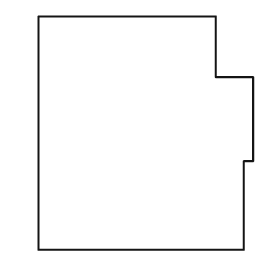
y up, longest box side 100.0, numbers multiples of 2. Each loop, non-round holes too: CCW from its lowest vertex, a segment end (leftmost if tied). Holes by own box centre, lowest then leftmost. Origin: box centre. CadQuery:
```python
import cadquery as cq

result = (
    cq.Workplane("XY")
    .moveTo(-46.0, -50.0)
    .lineTo(42.0, -50.0)
    .lineTo(42.0, -12.0)
    .lineTo(46.0, -12.0)
    .lineTo(46.0, 24.0)
    .lineTo(30.0, 24.0)
    .lineTo(30.0, 50.0)
    .lineTo(-46.0, 50.0)
    .close()
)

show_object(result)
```